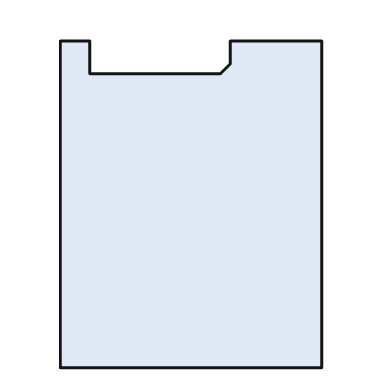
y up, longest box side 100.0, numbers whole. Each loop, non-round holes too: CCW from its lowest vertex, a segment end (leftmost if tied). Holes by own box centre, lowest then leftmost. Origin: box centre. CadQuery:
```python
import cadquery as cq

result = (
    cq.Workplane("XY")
    .moveTo(-40.0, -50.0)
    .lineTo(40.0, -50.0)
    .lineTo(40.0, 50.0)
    .lineTo(12.0, 50.0)
    .lineTo(12.0, 43.0)
    .lineTo(9.0, 40.0)
    .lineTo(-31.0, 40.0)
    .lineTo(-31.0, 50.0)
    .lineTo(-40.0, 50.0)
    .close()
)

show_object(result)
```